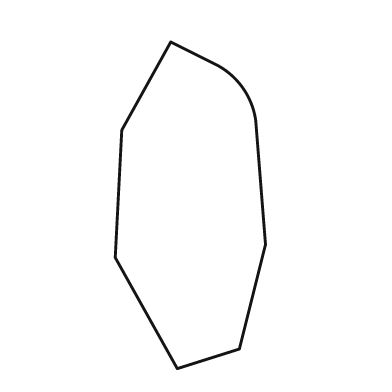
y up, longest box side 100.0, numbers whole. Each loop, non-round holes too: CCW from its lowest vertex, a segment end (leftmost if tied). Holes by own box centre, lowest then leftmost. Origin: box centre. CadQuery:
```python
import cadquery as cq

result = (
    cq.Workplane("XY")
    .moveTo(-4.0, -50.0)
    .lineTo(15.0, -44.0)
    .lineTo(23.0, -12.0)
    .lineTo(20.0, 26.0)
    .threePointArc((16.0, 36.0), (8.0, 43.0))
    .lineTo(-6.0, 50.0)
    .lineTo(-21.0, 23.0)
    .lineTo(-23.0, -16.0)
    .close()
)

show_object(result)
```